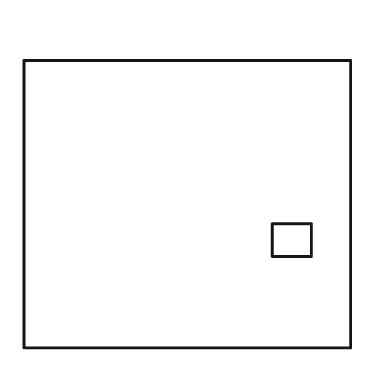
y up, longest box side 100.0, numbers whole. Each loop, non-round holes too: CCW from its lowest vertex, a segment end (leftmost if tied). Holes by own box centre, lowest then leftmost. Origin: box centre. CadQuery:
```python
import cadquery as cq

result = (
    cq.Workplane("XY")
    .moveTo(-50.0, -44.0)
    .lineTo(50.0, -44.0)
    .lineTo(50.0, 44.0)
    .lineTo(-50.0, 44.0)
    .close()
    .moveTo(26.0, -16.0)
    .lineTo(38.0, -16.0)
    .lineTo(38.0, -6.0)
    .lineTo(26.0, -6.0)
    .close()
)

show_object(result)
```